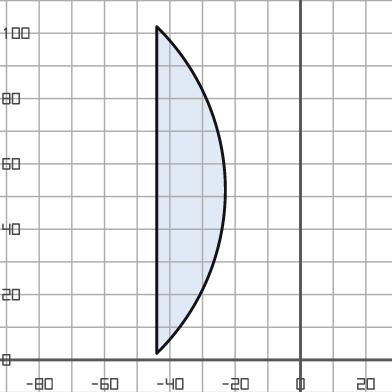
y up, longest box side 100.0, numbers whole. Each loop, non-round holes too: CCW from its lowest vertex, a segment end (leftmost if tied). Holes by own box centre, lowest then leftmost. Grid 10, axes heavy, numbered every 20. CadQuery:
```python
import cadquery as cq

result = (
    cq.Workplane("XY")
    .moveTo(-44.0, 2.0)
    .threePointArc((-23.0, 52.0), (-44.0, 102.0))
    .close()
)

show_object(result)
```